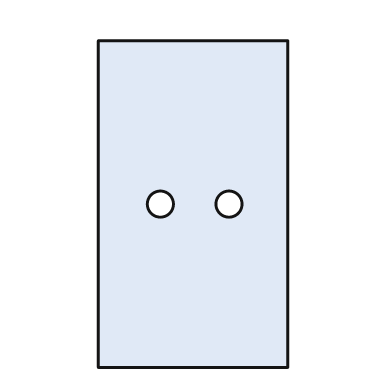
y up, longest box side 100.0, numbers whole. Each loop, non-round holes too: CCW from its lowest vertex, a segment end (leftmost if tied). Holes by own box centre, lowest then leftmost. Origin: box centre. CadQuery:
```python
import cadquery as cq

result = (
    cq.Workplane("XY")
    .moveTo(-29.0, -50.0)
    .lineTo(29.0, -50.0)
    .lineTo(29.0, 50.0)
    .lineTo(-29.0, 50.0)
    .close()
    .moveTo(-10.0, 0.0)
    .circle(4.0)
    .moveTo(11.0, 0.0)
    .circle(4.0)
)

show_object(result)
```